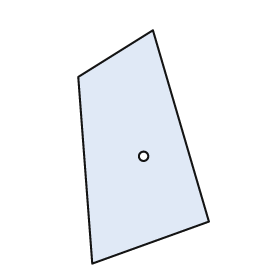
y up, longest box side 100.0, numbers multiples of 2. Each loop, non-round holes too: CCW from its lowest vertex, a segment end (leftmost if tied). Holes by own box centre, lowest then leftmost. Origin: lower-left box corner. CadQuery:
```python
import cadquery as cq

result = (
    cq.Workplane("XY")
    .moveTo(6.0, 0.0)
    .lineTo(56.0, 18.0)
    .lineTo(32.0, 100.0)
    .lineTo(0.0, 80.0)
    .close()
    .moveTo(28.0, 46.0)
    .circle(2.0)
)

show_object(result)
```